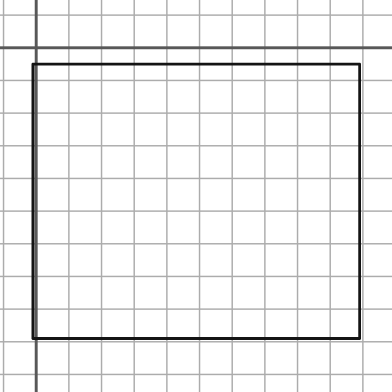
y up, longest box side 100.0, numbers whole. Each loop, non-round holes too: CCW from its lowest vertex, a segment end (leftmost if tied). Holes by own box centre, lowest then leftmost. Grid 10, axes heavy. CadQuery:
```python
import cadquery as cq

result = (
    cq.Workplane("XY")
    .moveTo(-1.0, -89.0)
    .lineTo(99.0, -89.0)
    .lineTo(99.0, -5.0)
    .lineTo(-1.0, -5.0)
    .close()
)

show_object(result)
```